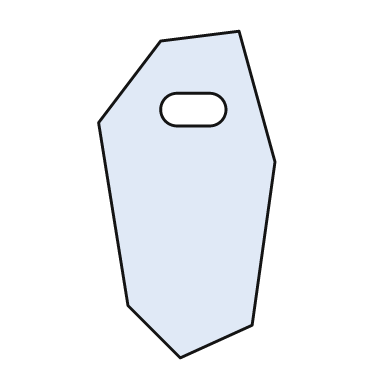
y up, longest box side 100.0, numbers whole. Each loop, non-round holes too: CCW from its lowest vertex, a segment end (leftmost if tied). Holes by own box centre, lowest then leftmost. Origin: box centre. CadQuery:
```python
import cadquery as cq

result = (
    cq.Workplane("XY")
    .moveTo(-2.0, -50.0)
    .lineTo(20.0, -40.0)
    .lineTo(27.0, 10.0)
    .lineTo(16.0, 50.0)
    .lineTo(-8.0, 47.0)
    .lineTo(-27.0, 22.0)
    .lineTo(-18.0, -34.0)
    .close()
    .moveTo(-3.0, 21.0)
    .lineTo(7.0, 21.0)
    .threePointArc((12.0, 26.0), (7.0, 31.0))
    .lineTo(-3.0, 31.0)
    .threePointArc((-8.0, 26.0), (-3.0, 21.0))
    .close()
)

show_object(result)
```